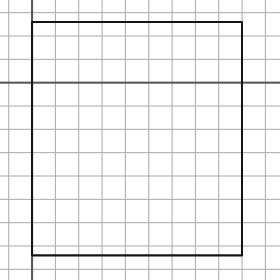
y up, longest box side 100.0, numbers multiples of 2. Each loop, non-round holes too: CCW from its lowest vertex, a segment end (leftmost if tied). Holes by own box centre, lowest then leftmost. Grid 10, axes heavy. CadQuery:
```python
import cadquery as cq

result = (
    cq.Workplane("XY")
    .moveTo(0.0, -74.0)
    .lineTo(90.0, -74.0)
    .lineTo(90.0, 26.0)
    .lineTo(0.0, 26.0)
    .close()
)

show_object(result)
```